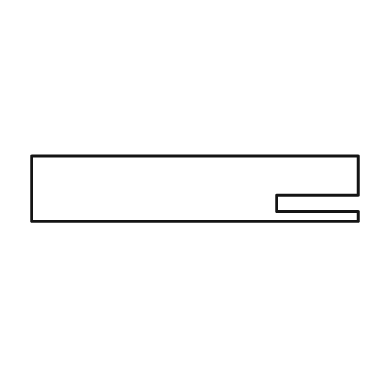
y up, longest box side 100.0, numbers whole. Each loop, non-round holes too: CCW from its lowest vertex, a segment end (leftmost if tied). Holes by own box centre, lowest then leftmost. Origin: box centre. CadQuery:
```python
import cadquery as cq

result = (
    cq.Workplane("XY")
    .moveTo(-50.0, -10.0)
    .lineTo(50.0, -10.0)
    .lineTo(50.0, -7.0)
    .lineTo(25.0, -7.0)
    .lineTo(25.0, -2.0)
    .lineTo(50.0, -2.0)
    .lineTo(50.0, 10.0)
    .lineTo(-50.0, 10.0)
    .close()
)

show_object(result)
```